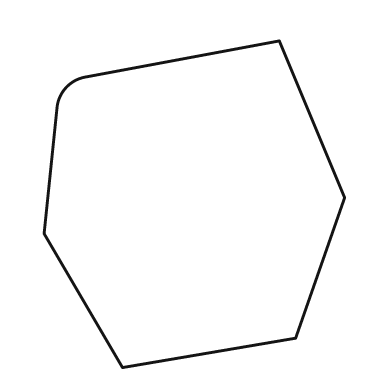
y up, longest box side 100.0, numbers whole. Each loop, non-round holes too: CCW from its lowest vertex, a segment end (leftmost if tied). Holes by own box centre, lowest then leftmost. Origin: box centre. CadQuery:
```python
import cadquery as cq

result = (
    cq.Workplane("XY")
    .moveTo(-22.0, -50.0)
    .lineTo(31.0, -41.0)
    .lineTo(46.0, 2.0)
    .lineTo(26.0, 50.0)
    .lineTo(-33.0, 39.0)
    .threePointArc((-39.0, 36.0), (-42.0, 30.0))
    .lineTo(-46.0, -9.0)
    .close()
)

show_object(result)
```